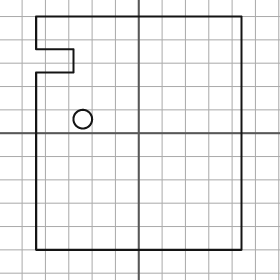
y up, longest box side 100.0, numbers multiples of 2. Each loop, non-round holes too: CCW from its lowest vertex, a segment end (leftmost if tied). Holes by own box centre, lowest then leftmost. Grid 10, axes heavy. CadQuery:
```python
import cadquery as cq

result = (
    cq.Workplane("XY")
    .moveTo(-44.0, -50.0)
    .lineTo(44.0, -50.0)
    .lineTo(44.0, 50.0)
    .lineTo(-44.0, 50.0)
    .lineTo(-44.0, 36.0)
    .lineTo(-28.0, 36.0)
    .lineTo(-28.0, 26.0)
    .lineTo(-44.0, 26.0)
    .close()
    .moveTo(-24.0, 6.0)
    .circle(4.0)
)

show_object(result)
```